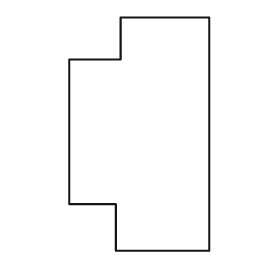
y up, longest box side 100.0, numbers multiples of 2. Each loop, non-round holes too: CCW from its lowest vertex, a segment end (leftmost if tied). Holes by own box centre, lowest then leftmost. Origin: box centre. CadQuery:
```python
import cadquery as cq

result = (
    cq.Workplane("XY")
    .moveTo(-10.0, -50.0)
    .lineTo(30.0, -50.0)
    .lineTo(30.0, 50.0)
    .lineTo(-8.0, 50.0)
    .lineTo(-8.0, 32.0)
    .lineTo(-30.0, 32.0)
    .lineTo(-30.0, -30.0)
    .lineTo(-10.0, -30.0)
    .close()
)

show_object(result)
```